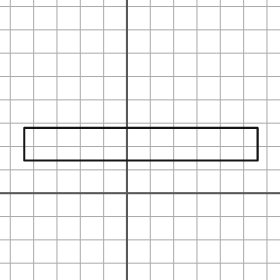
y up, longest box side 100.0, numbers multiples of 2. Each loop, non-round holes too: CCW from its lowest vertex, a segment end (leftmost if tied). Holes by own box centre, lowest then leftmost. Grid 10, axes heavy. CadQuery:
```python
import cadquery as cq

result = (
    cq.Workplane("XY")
    .moveTo(-44.0, 14.0)
    .lineTo(56.0, 14.0)
    .lineTo(56.0, 28.0)
    .lineTo(-44.0, 28.0)
    .close()
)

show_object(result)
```